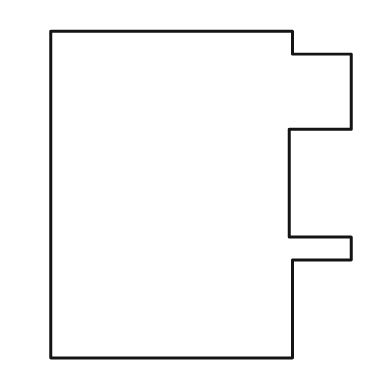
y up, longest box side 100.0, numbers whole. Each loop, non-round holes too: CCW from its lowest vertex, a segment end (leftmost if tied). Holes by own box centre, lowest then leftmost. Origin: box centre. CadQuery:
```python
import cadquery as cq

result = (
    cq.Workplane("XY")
    .moveTo(-46.0, -50.0)
    .lineTo(28.0, -50.0)
    .lineTo(28.0, -20.0)
    .lineTo(46.0, -20.0)
    .lineTo(46.0, -13.0)
    .lineTo(27.0, -13.0)
    .lineTo(27.0, 20.0)
    .lineTo(46.0, 20.0)
    .lineTo(46.0, 43.0)
    .lineTo(28.0, 43.0)
    .lineTo(28.0, 50.0)
    .lineTo(-46.0, 50.0)
    .close()
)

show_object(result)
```